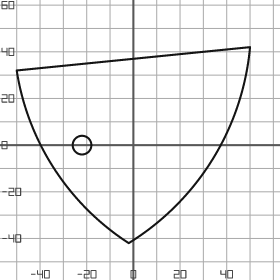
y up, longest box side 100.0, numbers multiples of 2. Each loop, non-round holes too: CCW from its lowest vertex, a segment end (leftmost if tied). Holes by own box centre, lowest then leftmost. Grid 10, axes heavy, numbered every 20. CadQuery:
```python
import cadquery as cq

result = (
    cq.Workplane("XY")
    .moveTo(-2.0, -42.0)
    .threePointArc((34.0, -6.0), (50.0, 42.0))
    .lineTo(-50.0, 32.0)
    .threePointArc((-34.0, -10.0), (-2.0, -42.0))
    .close()
    .moveTo(-22.0, 0.0)
    .circle(4.0)
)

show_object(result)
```